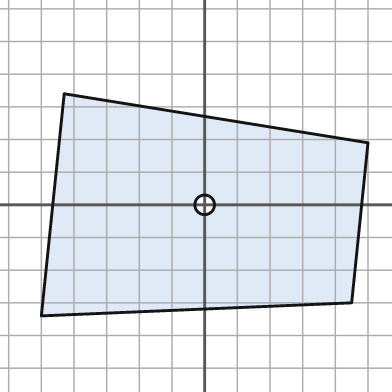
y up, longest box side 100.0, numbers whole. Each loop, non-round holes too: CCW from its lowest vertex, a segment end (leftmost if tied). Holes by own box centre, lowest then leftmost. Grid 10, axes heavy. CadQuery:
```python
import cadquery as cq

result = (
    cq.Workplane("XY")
    .moveTo(-50.0, -34.0)
    .lineTo(45.0, -30.0)
    .lineTo(50.0, 19.0)
    .lineTo(-43.0, 34.0)
    .close()
    .moveTo(0.0, 0.0)
    .circle(3.0)
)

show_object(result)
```